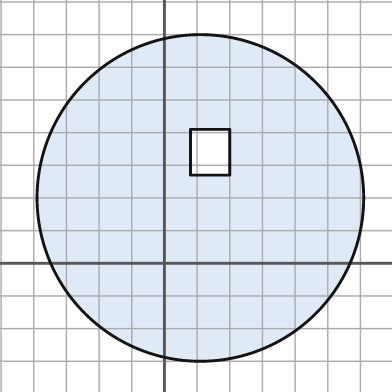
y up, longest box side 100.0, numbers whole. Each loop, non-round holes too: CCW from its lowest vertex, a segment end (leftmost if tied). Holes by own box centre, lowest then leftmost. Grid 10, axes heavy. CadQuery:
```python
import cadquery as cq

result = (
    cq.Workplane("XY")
    .moveTo(11.0, 20.0)
    .circle(50.0)
    .moveTo(8.0, 27.0)
    .lineTo(20.0, 27.0)
    .lineTo(20.0, 41.0)
    .lineTo(8.0, 41.0)
    .close()
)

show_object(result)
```